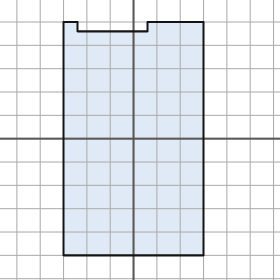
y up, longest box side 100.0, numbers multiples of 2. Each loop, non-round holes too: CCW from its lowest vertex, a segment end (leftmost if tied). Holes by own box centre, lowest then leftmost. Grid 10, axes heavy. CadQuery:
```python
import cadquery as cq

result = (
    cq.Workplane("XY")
    .moveTo(-30.0, -50.0)
    .lineTo(30.0, -50.0)
    .lineTo(30.0, 50.0)
    .lineTo(6.0, 50.0)
    .lineTo(6.0, 46.0)
    .lineTo(-24.0, 46.0)
    .lineTo(-24.0, 50.0)
    .lineTo(-30.0, 50.0)
    .close()
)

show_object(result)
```